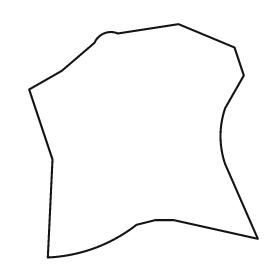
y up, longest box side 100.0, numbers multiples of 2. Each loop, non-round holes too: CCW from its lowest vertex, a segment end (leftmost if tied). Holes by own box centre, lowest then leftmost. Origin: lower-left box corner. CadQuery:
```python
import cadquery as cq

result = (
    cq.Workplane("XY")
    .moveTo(8.0, 0.0)
    .threePointArc((28.0, 4.0), (46.0, 14.0))
    .lineTo(54.0, 16.0)
    .lineTo(62.0, 16.0)
    .lineTo(98.0, 8.0)
    .lineTo(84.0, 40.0)
    .threePointArc((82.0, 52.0), (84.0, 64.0))
    .lineTo(92.0, 78.0)
    .lineTo(88.0, 90.0)
    .lineTo(64.0, 100.0)
    .lineTo(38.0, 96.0)
    .threePointArc((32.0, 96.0), (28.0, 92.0))
    .lineTo(14.0, 80.0)
    .lineTo(0.0, 72.0)
    .lineTo(10.0, 42.0)
    .close()
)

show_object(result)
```